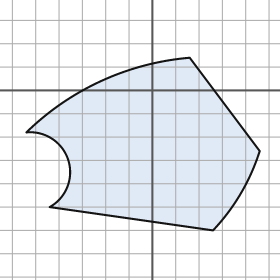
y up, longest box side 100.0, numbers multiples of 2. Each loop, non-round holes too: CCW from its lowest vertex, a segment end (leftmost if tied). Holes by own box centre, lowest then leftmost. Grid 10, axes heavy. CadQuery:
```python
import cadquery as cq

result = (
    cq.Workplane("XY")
    .moveTo(26.0, -60.0)
    .threePointArc((38.0, -44.0), (46.0, -26.0))
    .lineTo(16.0, 14.0)
    .threePointArc((-22.0, 4.0), (-54.0, -18.0))
    .threePointArc((-36.0, -30.0), (-44.0, -50.0))
    .close()
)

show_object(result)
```